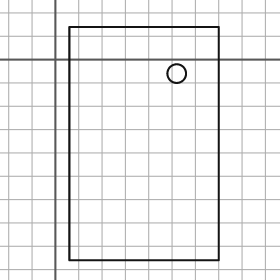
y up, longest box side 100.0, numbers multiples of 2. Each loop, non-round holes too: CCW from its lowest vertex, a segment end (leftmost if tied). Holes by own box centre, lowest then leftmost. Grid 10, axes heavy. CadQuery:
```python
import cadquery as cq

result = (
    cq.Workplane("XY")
    .moveTo(6.0, -86.0)
    .lineTo(70.0, -86.0)
    .lineTo(70.0, 14.0)
    .lineTo(6.0, 14.0)
    .close()
    .moveTo(52.0, -6.0)
    .circle(4.0)
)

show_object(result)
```